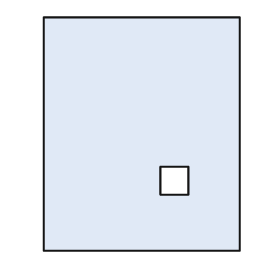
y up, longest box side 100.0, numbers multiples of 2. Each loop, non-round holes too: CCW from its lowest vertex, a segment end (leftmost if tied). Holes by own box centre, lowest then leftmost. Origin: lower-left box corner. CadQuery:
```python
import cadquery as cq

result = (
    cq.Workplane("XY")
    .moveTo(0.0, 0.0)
    .lineTo(84.0, 0.0)
    .lineTo(84.0, 100.0)
    .lineTo(0.0, 100.0)
    .close()
    .moveTo(50.0, 24.0)
    .lineTo(62.0, 24.0)
    .lineTo(62.0, 36.0)
    .lineTo(50.0, 36.0)
    .close()
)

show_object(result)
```